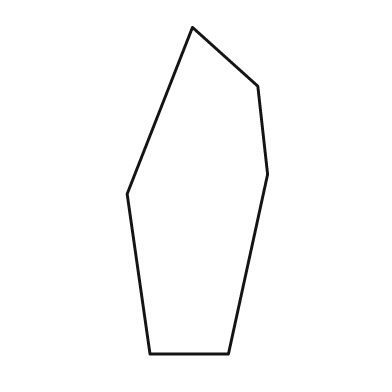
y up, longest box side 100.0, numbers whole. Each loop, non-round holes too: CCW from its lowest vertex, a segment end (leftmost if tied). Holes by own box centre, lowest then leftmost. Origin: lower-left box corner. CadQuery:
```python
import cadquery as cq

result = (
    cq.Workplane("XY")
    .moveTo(7.0, 0.0)
    .lineTo(31.0, 0.0)
    .lineTo(43.0, 55.0)
    .lineTo(40.0, 82.0)
    .lineTo(20.0, 100.0)
    .lineTo(0.0, 49.0)
    .close()
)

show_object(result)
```